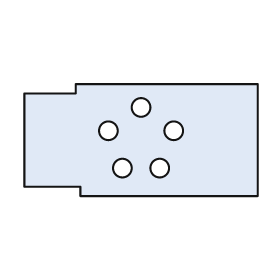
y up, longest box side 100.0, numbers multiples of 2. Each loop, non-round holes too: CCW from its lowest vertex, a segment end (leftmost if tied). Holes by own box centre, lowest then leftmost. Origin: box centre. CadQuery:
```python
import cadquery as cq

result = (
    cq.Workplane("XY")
    .moveTo(-26.0, -24.0)
    .lineTo(50.0, -24.0)
    .lineTo(50.0, 24.0)
    .lineTo(-28.0, 24.0)
    .lineTo(-28.0, 20.0)
    .lineTo(-50.0, 20.0)
    .lineTo(-50.0, -20.0)
    .lineTo(-26.0, -20.0)
    .close()
    .moveTo(-8.0, -12.0)
    .circle(4.0)
    .moveTo(8.0, -12.0)
    .circle(4.0)
    .moveTo(-14.0, 4.0)
    .circle(4.0)
    .moveTo(14.0, 4.0)
    .circle(4.0)
    .moveTo(0.0, 14.0)
    .circle(4.0)
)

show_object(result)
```